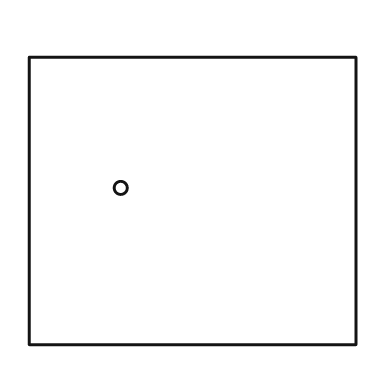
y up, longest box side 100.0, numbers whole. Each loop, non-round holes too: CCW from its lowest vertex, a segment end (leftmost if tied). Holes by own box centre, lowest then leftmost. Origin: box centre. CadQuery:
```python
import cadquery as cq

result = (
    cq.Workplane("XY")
    .moveTo(-50.0, -44.0)
    .lineTo(50.0, -44.0)
    .lineTo(50.0, 44.0)
    .lineTo(-50.0, 44.0)
    .close()
    .moveTo(-22.0, 4.0)
    .circle(2.0)
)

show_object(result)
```